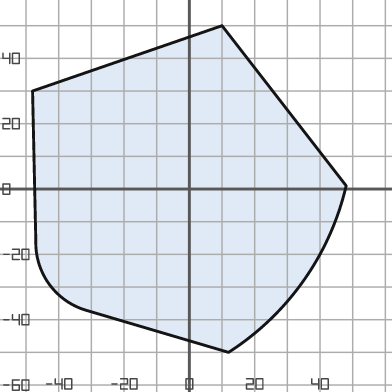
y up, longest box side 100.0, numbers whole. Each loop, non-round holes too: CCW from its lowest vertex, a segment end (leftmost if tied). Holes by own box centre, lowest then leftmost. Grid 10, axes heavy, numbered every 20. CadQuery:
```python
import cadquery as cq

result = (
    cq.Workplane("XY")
    .moveTo(12.0, -50.0)
    .threePointArc((35.0, -28.0), (48.0, 1.0))
    .lineTo(10.0, 50.0)
    .lineTo(-48.0, 30.0)
    .lineTo(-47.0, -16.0)
    .threePointArc((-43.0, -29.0), (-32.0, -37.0))
    .close()
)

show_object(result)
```